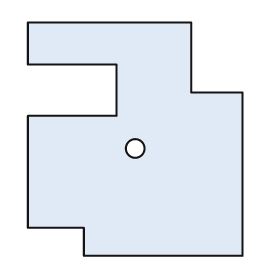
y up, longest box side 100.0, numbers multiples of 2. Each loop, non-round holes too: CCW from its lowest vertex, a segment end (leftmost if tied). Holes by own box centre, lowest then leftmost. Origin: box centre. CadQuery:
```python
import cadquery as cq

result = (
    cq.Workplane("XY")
    .moveTo(-22.0, -50.0)
    .lineTo(46.0, -50.0)
    .lineTo(46.0, 20.0)
    .lineTo(24.0, 20.0)
    .lineTo(24.0, 50.0)
    .lineTo(-46.0, 50.0)
    .lineTo(-46.0, 32.0)
    .lineTo(-8.0, 32.0)
    .lineTo(-8.0, 10.0)
    .lineTo(-46.0, 10.0)
    .lineTo(-46.0, -38.0)
    .lineTo(-22.0, -38.0)
    .close()
    .moveTo(0.0, -4.0)
    .circle(4.0)
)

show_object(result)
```